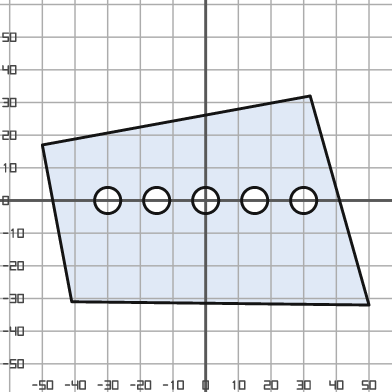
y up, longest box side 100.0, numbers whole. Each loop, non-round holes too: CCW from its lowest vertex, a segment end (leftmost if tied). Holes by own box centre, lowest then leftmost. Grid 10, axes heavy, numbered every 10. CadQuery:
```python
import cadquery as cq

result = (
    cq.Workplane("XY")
    .moveTo(50.0, -32.0)
    .lineTo(32.0, 32.0)
    .lineTo(-50.0, 17.0)
    .lineTo(-41.0, -31.0)
    .close()
    .moveTo(-30.0, 0.0)
    .circle(4.0)
    .moveTo(-15.0, 0.0)
    .circle(4.0)
    .moveTo(0.0, 0.0)
    .circle(4.0)
    .moveTo(15.0, 0.0)
    .circle(4.0)
    .moveTo(30.0, 0.0)
    .circle(4.0)
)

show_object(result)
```